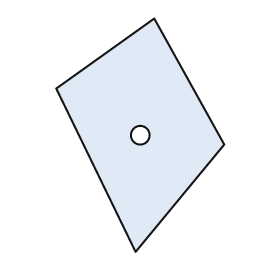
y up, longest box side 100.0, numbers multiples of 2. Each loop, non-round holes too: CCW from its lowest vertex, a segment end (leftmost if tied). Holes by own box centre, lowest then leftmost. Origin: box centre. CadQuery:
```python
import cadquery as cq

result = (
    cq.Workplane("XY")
    .moveTo(-2.0, -50.0)
    .lineTo(36.0, -4.0)
    .lineTo(6.0, 50.0)
    .lineTo(-36.0, 20.0)
    .close()
    .moveTo(0.0, 0.0)
    .circle(4.0)
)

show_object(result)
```